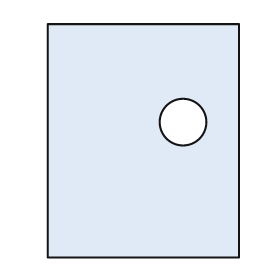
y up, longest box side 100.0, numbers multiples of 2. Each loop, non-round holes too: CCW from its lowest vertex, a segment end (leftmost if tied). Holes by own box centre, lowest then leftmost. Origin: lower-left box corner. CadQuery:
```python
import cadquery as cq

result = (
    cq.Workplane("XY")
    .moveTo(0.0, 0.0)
    .lineTo(82.0, 0.0)
    .lineTo(82.0, 100.0)
    .lineTo(0.0, 100.0)
    .close()
    .moveTo(58.0, 58.0)
    .circle(10.0)
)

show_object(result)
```